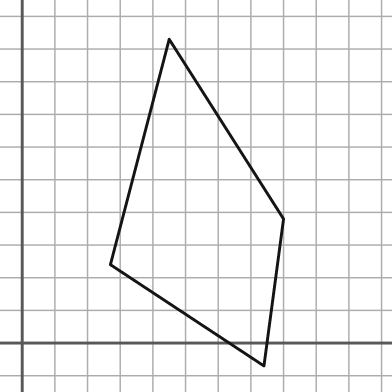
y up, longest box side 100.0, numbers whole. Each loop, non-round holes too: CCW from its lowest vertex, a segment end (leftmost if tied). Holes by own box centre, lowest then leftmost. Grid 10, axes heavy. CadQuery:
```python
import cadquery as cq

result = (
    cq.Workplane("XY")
    .moveTo(74.0, -7.0)
    .lineTo(80.0, 38.0)
    .lineTo(45.0, 93.0)
    .lineTo(27.0, 24.0)
    .close()
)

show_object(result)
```